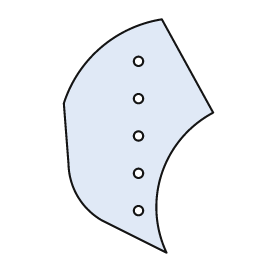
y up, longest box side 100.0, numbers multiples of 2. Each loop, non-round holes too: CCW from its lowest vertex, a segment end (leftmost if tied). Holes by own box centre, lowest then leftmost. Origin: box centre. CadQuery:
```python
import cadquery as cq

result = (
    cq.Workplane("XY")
    .moveTo(12.0, -50.0)
    .threePointArc((10.0, -16.0), (32.0, 10.0))
    .lineTo(10.0, 50.0)
    .threePointArc((-16.0, 38.0), (-32.0, 14.0))
    .lineTo(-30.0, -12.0)
    .threePointArc((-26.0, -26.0), (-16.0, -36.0))
    .close()
    .moveTo(0.0, -32.0)
    .circle(2.0)
    .moveTo(0.0, -16.0)
    .circle(2.0)
    .moveTo(0.0, 0.0)
    .circle(2.0)
    .moveTo(0.0, 16.0)
    .circle(2.0)
    .moveTo(0.0, 32.0)
    .circle(2.0)
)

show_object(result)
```